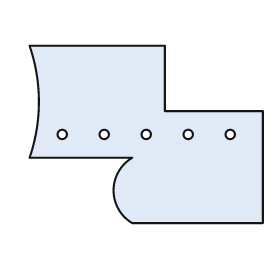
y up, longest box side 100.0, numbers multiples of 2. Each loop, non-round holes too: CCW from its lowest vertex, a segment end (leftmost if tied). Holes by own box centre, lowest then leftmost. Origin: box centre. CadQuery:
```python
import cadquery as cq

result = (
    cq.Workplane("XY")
    .moveTo(-6.0, -38.0)
    .lineTo(50.0, -38.0)
    .lineTo(50.0, 10.0)
    .lineTo(8.0, 10.0)
    .lineTo(8.0, 38.0)
    .lineTo(-50.0, 38.0)
    .threePointArc((-46.0, 14.0), (-50.0, -10.0))
    .lineTo(-6.0, -10.0)
    .threePointArc((-14.0, -24.0), (-6.0, -38.0))
    .close()
    .moveTo(-36.0, 0.0)
    .circle(2.0)
    .moveTo(-18.0, 0.0)
    .circle(2.0)
    .moveTo(0.0, 0.0)
    .circle(2.0)
    .moveTo(18.0, 0.0)
    .circle(2.0)
    .moveTo(36.0, 0.0)
    .circle(2.0)
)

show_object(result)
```